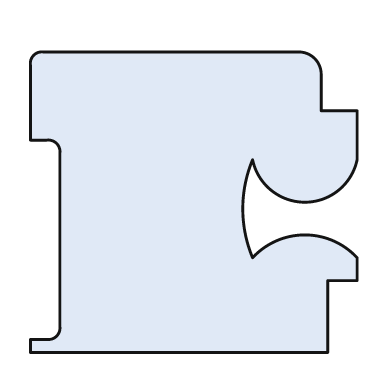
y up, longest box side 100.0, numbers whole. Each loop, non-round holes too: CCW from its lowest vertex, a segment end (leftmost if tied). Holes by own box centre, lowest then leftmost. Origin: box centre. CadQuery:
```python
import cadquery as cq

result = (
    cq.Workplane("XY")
    .moveTo(-50.0, -46.0)
    .lineTo(41.0, -46.0)
    .lineTo(41.0, -24.0)
    .lineTo(50.0, -24.0)
    .lineTo(50.0, -17.0)
    .threePointArc((34.0, -10.0), (18.0, -17.0))
    .threePointArc((15.0, -2.0), (18.0, 13.0))
    .threePointArc((34.0, 0.0), (50.0, 13.0))
    .lineTo(50.0, 28.0)
    .lineTo(39.0, 28.0)
    .lineTo(39.0, 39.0)
    .threePointArc((37.0, 44.0), (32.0, 46.0))
    .lineTo(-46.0, 46.0)
    .threePointArc((-49.0, 45.0), (-50.0, 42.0))
    .lineTo(-50.0, 19.0)
    .lineTo(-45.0, 19.0)
    .threePointArc((-42.0, 18.0), (-41.0, 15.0))
    .lineTo(-41.0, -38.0)
    .threePointArc((-42.0, -41.0), (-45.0, -42.0))
    .lineTo(-50.0, -42.0)
    .close()
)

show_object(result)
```